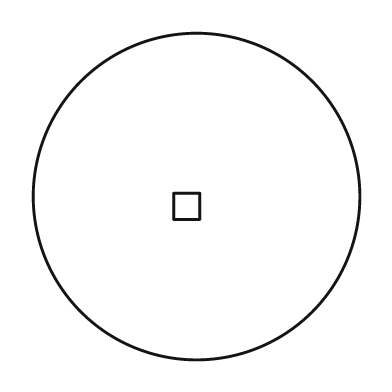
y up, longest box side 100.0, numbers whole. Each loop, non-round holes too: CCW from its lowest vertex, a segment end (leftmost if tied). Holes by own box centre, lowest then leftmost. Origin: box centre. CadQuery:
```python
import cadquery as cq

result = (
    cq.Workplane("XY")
    .moveTo(0.0, 0.0)
    .circle(50.0)
    .moveTo(-7.0, -7.0)
    .lineTo(1.0, -7.0)
    .lineTo(1.0, 1.0)
    .lineTo(-7.0, 1.0)
    .close()
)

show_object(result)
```